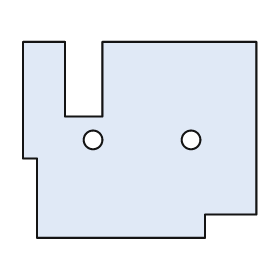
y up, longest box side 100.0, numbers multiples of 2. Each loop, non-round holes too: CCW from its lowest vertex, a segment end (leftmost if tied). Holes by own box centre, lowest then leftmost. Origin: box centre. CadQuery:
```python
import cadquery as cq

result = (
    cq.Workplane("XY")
    .moveTo(-44.0, -42.0)
    .lineTo(28.0, -42.0)
    .lineTo(28.0, -32.0)
    .lineTo(50.0, -32.0)
    .lineTo(50.0, 42.0)
    .lineTo(-16.0, 42.0)
    .lineTo(-16.0, 10.0)
    .lineTo(-32.0, 10.0)
    .lineTo(-32.0, 42.0)
    .lineTo(-50.0, 42.0)
    .lineTo(-50.0, -8.0)
    .lineTo(-44.0, -8.0)
    .close()
    .moveTo(-20.0, 0.0)
    .circle(4.0)
    .moveTo(22.0, 0.0)
    .circle(4.0)
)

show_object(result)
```